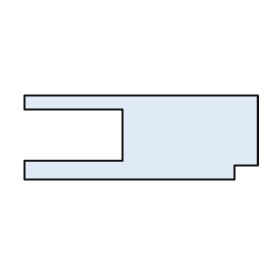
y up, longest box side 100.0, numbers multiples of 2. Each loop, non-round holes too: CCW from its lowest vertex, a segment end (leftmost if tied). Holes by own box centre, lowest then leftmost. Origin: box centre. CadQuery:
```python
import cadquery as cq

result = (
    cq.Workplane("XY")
    .moveTo(-50.0, -18.0)
    .lineTo(40.0, -18.0)
    .lineTo(40.0, -12.0)
    .lineTo(50.0, -12.0)
    .lineTo(50.0, 18.0)
    .lineTo(-50.0, 18.0)
    .lineTo(-50.0, 12.0)
    .lineTo(-8.0, 12.0)
    .lineTo(-8.0, -10.0)
    .lineTo(-50.0, -10.0)
    .close()
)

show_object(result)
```